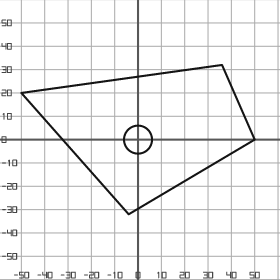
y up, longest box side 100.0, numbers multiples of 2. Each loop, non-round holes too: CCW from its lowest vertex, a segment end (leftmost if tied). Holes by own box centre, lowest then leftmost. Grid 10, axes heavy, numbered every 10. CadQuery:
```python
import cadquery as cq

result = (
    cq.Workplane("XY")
    .moveTo(-4.0, -32.0)
    .lineTo(50.0, 0.0)
    .lineTo(36.0, 32.0)
    .lineTo(-50.0, 20.0)
    .close()
    .moveTo(0.0, 0.0)
    .circle(6.0)
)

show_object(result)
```